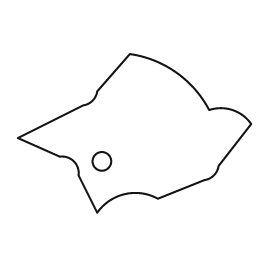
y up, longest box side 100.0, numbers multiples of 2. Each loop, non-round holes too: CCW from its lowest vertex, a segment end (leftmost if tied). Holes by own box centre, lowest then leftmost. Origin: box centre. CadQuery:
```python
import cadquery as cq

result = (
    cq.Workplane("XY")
    .moveTo(-16.0, -34.0)
    .threePointArc((-4.0, -26.0), (10.0, -28.0))
    .lineTo(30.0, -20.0)
    .threePointArc((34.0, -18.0), (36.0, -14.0))
    .lineTo(50.0, 4.0)
    .threePointArc((42.0, 10.0), (32.0, 10.0))
    .threePointArc((18.0, 26.0), (-2.0, 34.0))
    .lineTo(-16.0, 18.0)
    .threePointArc((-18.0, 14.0), (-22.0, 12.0))
    .lineTo(-50.0, -2.0)
    .lineTo(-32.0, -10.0)
    .threePointArc((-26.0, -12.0), (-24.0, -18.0))
    .close()
    .moveTo(-14.0, -12.0)
    .circle(4.0)
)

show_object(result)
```